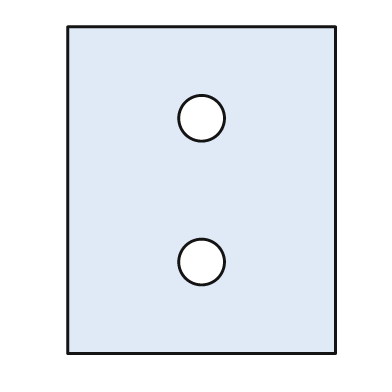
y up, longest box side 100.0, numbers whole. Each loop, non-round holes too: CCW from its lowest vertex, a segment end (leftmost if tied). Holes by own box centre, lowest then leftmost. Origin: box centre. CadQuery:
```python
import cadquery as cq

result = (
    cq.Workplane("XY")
    .moveTo(-41.0, -50.0)
    .lineTo(41.0, -50.0)
    .lineTo(41.0, 50.0)
    .lineTo(-41.0, 50.0)
    .close()
    .moveTo(0.0, -22.0)
    .circle(7.0)
    .moveTo(0.0, 22.0)
    .circle(7.0)
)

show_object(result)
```